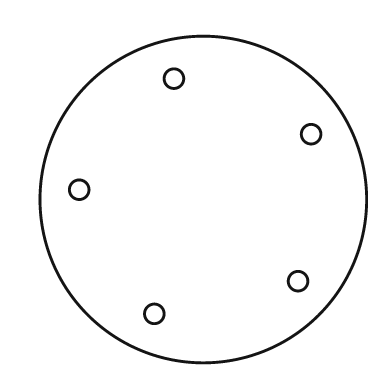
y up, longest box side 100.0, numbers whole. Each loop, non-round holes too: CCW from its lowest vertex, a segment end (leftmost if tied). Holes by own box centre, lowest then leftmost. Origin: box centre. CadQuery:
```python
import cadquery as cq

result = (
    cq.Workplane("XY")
    .moveTo(0.0, 0.0)
    .circle(50.0)
    .moveTo(-15.0, -35.0)
    .circle(3.0)
    .moveTo(29.0, -25.0)
    .circle(3.0)
    .moveTo(-38.0, 3.0)
    .circle(3.0)
    .moveTo(33.0, 20.0)
    .circle(3.0)
    .moveTo(-9.0, 37.0)
    .circle(3.0)
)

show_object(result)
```